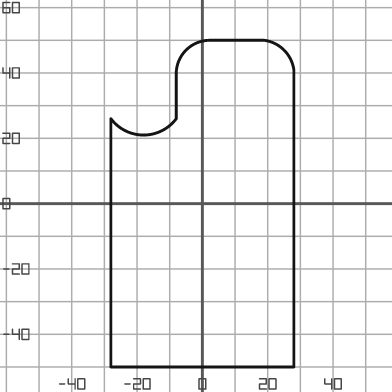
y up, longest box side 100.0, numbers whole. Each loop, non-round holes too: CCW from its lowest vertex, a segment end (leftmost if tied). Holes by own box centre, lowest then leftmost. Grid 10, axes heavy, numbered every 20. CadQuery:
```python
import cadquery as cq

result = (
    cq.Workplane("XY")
    .moveTo(-28.0, -50.0)
    .lineTo(28.0, -50.0)
    .lineTo(28.0, 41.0)
    .threePointArc((25.0, 47.0), (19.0, 50.0))
    .lineTo(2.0, 50.0)
    .threePointArc((-5.0, 47.0), (-8.0, 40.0))
    .lineTo(-8.0, 26.0)
    .threePointArc((-18.0, 21.0), (-28.0, 26.0))
    .close()
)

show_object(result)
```